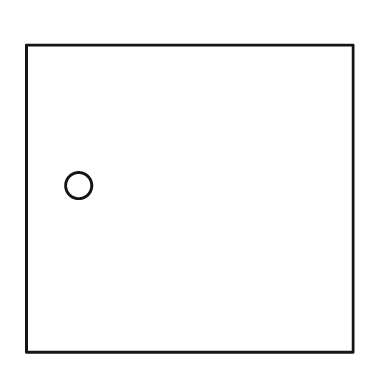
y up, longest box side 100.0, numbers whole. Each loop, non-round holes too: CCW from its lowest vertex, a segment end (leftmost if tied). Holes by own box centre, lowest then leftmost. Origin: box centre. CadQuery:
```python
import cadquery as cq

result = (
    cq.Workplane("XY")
    .moveTo(-50.0, -47.0)
    .lineTo(50.0, -47.0)
    .lineTo(50.0, 47.0)
    .lineTo(-50.0, 47.0)
    .close()
    .moveTo(-34.0, 4.0)
    .circle(4.0)
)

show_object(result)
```